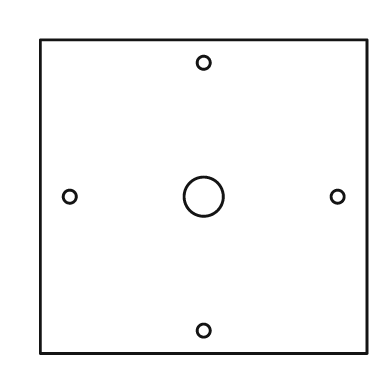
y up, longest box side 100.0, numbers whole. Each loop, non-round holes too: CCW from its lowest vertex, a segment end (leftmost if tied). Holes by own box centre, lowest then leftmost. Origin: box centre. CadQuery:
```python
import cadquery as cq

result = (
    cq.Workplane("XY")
    .moveTo(-50.0, -48.0)
    .lineTo(50.0, -48.0)
    .lineTo(50.0, 48.0)
    .lineTo(-50.0, 48.0)
    .close()
    .moveTo(0.0, -41.0)
    .circle(2.0)
    .moveTo(-41.0, 0.0)
    .circle(2.0)
    .moveTo(0.0, 0.0)
    .circle(6.0)
    .moveTo(41.0, 0.0)
    .circle(2.0)
    .moveTo(0.0, 41.0)
    .circle(2.0)
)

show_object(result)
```